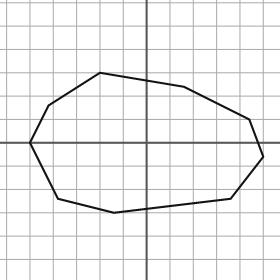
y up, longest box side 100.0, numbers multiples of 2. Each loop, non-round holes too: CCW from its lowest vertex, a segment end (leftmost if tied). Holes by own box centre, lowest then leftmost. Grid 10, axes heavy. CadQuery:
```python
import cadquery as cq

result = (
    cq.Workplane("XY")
    .moveTo(-14.0, -30.0)
    .lineTo(36.0, -24.0)
    .lineTo(50.0, -6.0)
    .lineTo(44.0, 10.0)
    .lineTo(16.0, 24.0)
    .lineTo(-20.0, 30.0)
    .lineTo(-42.0, 16.0)
    .lineTo(-50.0, 0.0)
    .lineTo(-38.0, -24.0)
    .close()
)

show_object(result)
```